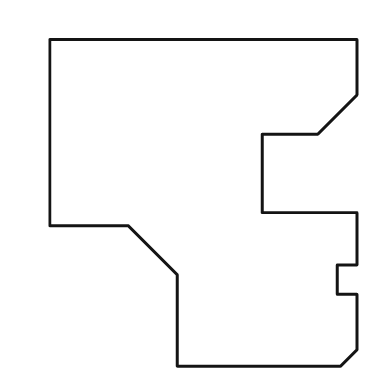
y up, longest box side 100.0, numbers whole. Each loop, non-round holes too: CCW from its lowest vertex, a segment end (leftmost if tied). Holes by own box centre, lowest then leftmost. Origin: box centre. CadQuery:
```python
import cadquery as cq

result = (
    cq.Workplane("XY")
    .moveTo(-8.0, -50.0)
    .lineTo(42.0, -50.0)
    .lineTo(47.0, -45.0)
    .lineTo(47.0, -28.0)
    .lineTo(41.0, -28.0)
    .lineTo(41.0, -19.0)
    .lineTo(47.0, -19.0)
    .lineTo(47.0, -3.0)
    .lineTo(18.0, -3.0)
    .lineTo(18.0, 21.0)
    .lineTo(35.0, 21.0)
    .lineTo(47.0, 33.0)
    .lineTo(47.0, 50.0)
    .lineTo(-47.0, 50.0)
    .lineTo(-47.0, -7.0)
    .lineTo(-23.0, -7.0)
    .lineTo(-8.0, -22.0)
    .close()
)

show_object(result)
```